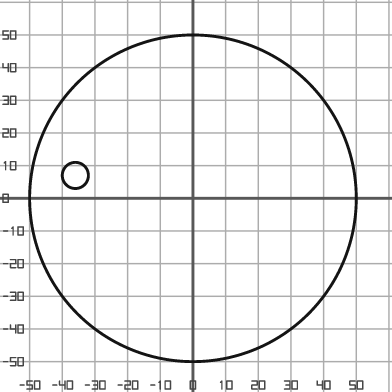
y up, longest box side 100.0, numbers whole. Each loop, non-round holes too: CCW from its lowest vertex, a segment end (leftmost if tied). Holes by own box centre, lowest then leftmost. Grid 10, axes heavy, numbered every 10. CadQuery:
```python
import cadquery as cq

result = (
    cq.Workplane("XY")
    .moveTo(0.0, 0.0)
    .circle(50.0)
    .moveTo(-36.0, 7.0)
    .circle(4.0)
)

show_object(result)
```